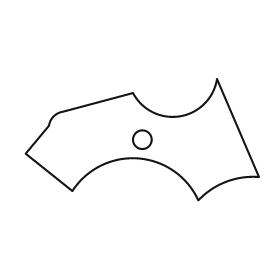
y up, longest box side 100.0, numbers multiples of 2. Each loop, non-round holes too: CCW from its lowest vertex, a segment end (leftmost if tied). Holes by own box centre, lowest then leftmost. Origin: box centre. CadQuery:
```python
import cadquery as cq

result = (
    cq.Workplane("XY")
    .moveTo(24.0, -26.0)
    .threePointArc((36.0, -18.0), (50.0, -16.0))
    .lineTo(32.0, 26.0)
    .threePointArc((16.0, 10.0), (-4.0, 20.0))
    .lineTo(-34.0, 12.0)
    .threePointArc((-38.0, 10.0), (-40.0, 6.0))
    .lineTo(-50.0, -6.0)
    .lineTo(-30.0, -22.0)
    .threePointArc((-2.0, -8.0), (24.0, -26.0))
    .close()
    .moveTo(0.0, 0.0)
    .circle(4.0)
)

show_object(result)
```